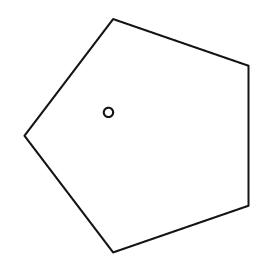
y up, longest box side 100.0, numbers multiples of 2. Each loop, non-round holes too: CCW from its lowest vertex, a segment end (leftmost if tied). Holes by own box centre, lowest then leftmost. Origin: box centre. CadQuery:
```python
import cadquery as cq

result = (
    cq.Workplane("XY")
    .moveTo(-10.0, -50.0)
    .lineTo(48.0, -30.0)
    .lineTo(48.0, 30.0)
    .lineTo(-10.0, 50.0)
    .lineTo(-48.0, 0.0)
    .close()
    .moveTo(-12.0, 10.0)
    .circle(2.0)
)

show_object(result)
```